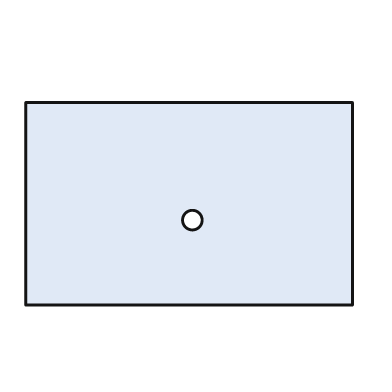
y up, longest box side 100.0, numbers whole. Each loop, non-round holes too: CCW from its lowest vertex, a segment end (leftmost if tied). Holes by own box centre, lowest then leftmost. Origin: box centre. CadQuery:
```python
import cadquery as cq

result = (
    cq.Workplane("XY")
    .moveTo(-50.0, -31.0)
    .lineTo(50.0, -31.0)
    .lineTo(50.0, 31.0)
    .lineTo(-50.0, 31.0)
    .close()
    .moveTo(1.0, -5.0)
    .circle(3.0)
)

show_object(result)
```